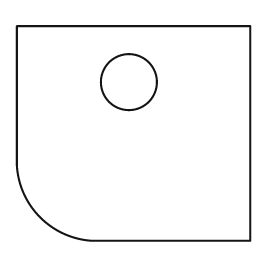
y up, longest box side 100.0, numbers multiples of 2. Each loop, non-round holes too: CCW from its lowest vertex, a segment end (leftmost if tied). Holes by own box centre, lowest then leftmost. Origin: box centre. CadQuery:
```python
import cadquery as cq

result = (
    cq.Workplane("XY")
    .moveTo(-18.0, -46.0)
    .lineTo(50.0, -46.0)
    .lineTo(50.0, 46.0)
    .lineTo(-50.0, 46.0)
    .lineTo(-50.0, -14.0)
    .threePointArc((-40.0, -36.0), (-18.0, -46.0))
    .close()
    .moveTo(-2.0, 22.0)
    .circle(12.0)
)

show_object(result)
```